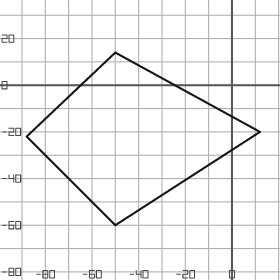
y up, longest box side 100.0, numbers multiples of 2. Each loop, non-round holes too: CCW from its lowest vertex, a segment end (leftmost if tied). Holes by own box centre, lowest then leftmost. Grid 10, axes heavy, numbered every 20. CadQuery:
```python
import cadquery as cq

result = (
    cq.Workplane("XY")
    .moveTo(-50.0, -60.0)
    .lineTo(12.0, -20.0)
    .lineTo(-50.0, 14.0)
    .lineTo(-88.0, -22.0)
    .close()
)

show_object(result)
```